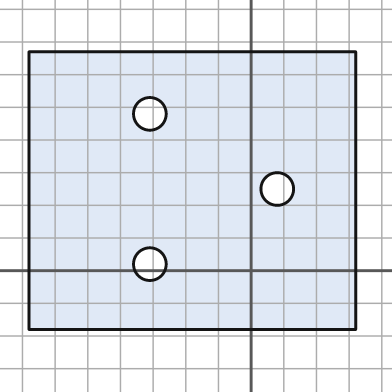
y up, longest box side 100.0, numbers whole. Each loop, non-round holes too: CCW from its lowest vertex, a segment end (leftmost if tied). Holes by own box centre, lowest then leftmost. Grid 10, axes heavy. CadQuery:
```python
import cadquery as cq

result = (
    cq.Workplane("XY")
    .moveTo(-68.0, -18.0)
    .lineTo(32.0, -18.0)
    .lineTo(32.0, 67.0)
    .lineTo(-68.0, 67.0)
    .close()
    .moveTo(-31.0, 2.0)
    .circle(5.0)
    .moveTo(8.0, 25.0)
    .circle(5.0)
    .moveTo(-31.0, 48.0)
    .circle(5.0)
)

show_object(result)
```